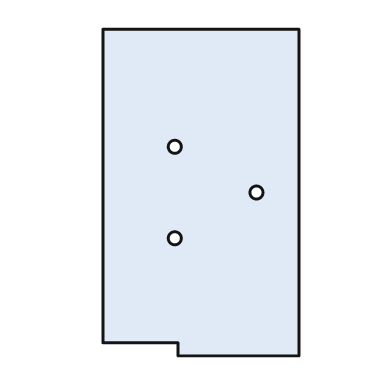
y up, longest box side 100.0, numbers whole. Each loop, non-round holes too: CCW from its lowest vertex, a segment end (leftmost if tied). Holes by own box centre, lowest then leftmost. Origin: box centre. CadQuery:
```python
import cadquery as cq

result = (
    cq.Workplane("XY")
    .moveTo(-7.0, -50.0)
    .lineTo(30.0, -50.0)
    .lineTo(30.0, 50.0)
    .lineTo(-30.0, 50.0)
    .lineTo(-30.0, -46.0)
    .lineTo(-7.0, -46.0)
    .close()
    .moveTo(-8.0, -14.0)
    .circle(2.0)
    .moveTo(17.0, 0.0)
    .circle(2.0)
    .moveTo(-8.0, 14.0)
    .circle(2.0)
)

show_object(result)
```